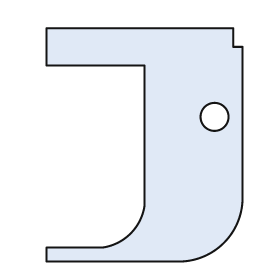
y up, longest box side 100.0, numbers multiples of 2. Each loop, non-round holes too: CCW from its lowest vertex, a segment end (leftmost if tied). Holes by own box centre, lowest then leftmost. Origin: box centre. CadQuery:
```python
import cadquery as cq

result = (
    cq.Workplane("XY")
    .moveTo(-42.0, -50.0)
    .lineTo(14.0, -50.0)
    .threePointArc((34.0, -42.0), (42.0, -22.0))
    .lineTo(42.0, 42.0)
    .lineTo(38.0, 42.0)
    .lineTo(38.0, 50.0)
    .lineTo(-42.0, 50.0)
    .lineTo(-42.0, 34.0)
    .lineTo(0.0, 34.0)
    .lineTo(0.0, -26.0)
    .threePointArc((-6.0, -38.0), (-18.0, -44.0))
    .lineTo(-42.0, -44.0)
    .close()
    .moveTo(30.0, 12.0)
    .circle(6.0)
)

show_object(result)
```